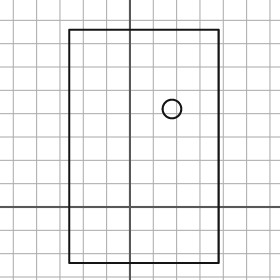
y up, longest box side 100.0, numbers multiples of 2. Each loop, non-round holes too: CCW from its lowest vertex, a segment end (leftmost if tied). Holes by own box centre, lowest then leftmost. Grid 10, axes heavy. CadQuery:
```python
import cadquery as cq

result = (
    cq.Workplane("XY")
    .moveTo(-26.0, -24.0)
    .lineTo(38.0, -24.0)
    .lineTo(38.0, 76.0)
    .lineTo(-26.0, 76.0)
    .close()
    .moveTo(18.0, 42.0)
    .circle(4.0)
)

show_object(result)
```